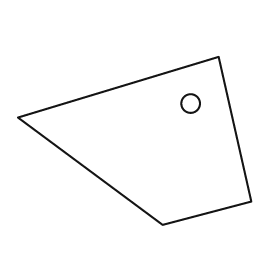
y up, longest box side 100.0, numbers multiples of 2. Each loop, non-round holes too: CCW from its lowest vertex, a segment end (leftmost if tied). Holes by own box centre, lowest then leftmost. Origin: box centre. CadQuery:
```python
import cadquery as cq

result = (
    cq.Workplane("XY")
    .moveTo(12.0, -36.0)
    .lineTo(50.0, -26.0)
    .lineTo(36.0, 36.0)
    .lineTo(-50.0, 10.0)
    .close()
    .moveTo(24.0, 16.0)
    .circle(4.0)
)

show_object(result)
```